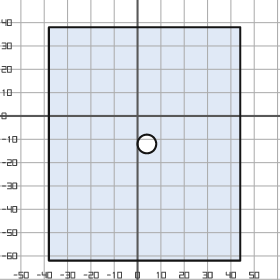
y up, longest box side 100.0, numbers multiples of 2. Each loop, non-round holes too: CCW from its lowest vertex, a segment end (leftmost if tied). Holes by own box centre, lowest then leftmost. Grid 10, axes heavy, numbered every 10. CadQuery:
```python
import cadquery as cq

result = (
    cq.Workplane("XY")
    .moveTo(-38.0, -62.0)
    .lineTo(44.0, -62.0)
    .lineTo(44.0, 38.0)
    .lineTo(-38.0, 38.0)
    .close()
    .moveTo(4.0, -12.0)
    .circle(4.0)
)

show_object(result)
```